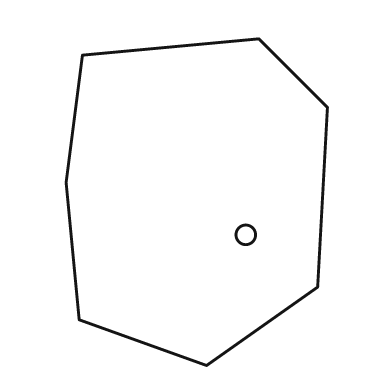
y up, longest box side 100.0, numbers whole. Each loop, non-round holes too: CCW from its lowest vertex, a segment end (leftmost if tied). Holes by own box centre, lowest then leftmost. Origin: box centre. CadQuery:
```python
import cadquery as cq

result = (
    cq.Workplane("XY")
    .moveTo(3.0, -50.0)
    .lineTo(37.0, -26.0)
    .lineTo(40.0, 29.0)
    .lineTo(19.0, 50.0)
    .lineTo(-35.0, 45.0)
    .lineTo(-40.0, 6.0)
    .lineTo(-36.0, -36.0)
    .close()
    .moveTo(15.0, -10.0)
    .circle(3.0)
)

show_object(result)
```